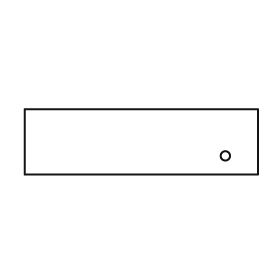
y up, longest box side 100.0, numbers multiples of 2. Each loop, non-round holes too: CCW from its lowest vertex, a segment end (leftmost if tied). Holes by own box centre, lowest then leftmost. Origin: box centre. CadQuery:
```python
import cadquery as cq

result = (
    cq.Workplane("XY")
    .moveTo(-50.0, -14.0)
    .lineTo(50.0, -14.0)
    .lineTo(50.0, 14.0)
    .lineTo(-50.0, 14.0)
    .close()
    .moveTo(36.0, -6.0)
    .circle(2.0)
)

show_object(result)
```